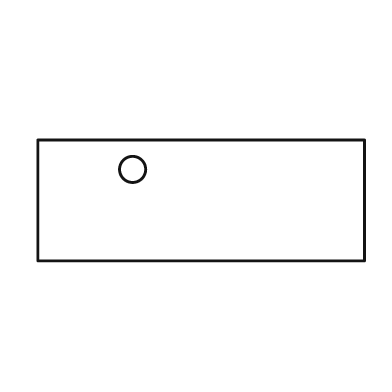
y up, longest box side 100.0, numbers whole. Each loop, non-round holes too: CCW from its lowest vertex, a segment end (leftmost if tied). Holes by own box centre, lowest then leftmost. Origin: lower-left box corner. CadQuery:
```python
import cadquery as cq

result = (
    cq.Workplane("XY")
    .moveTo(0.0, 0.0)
    .lineTo(100.0, 0.0)
    .lineTo(100.0, 37.0)
    .lineTo(0.0, 37.0)
    .close()
    .moveTo(29.0, 28.0)
    .circle(4.0)
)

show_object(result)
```